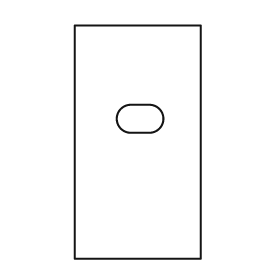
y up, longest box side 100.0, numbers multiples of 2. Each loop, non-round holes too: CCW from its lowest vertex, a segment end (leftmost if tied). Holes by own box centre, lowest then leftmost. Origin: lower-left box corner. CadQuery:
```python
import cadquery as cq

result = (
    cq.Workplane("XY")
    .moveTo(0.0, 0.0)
    .lineTo(54.0, 0.0)
    .lineTo(54.0, 100.0)
    .lineTo(0.0, 100.0)
    .close()
    .moveTo(24.0, 54.0)
    .lineTo(32.0, 54.0)
    .threePointArc((38.0, 60.0), (32.0, 66.0))
    .lineTo(24.0, 66.0)
    .threePointArc((18.0, 60.0), (24.0, 54.0))
    .close()
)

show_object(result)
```